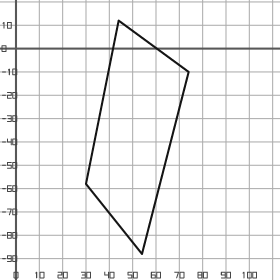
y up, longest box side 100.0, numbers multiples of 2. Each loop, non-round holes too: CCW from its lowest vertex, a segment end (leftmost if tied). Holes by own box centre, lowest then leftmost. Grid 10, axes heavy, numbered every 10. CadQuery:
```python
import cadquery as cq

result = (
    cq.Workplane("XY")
    .moveTo(54.0, -88.0)
    .lineTo(74.0, -10.0)
    .lineTo(44.0, 12.0)
    .lineTo(30.0, -58.0)
    .close()
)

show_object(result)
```